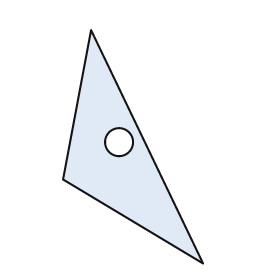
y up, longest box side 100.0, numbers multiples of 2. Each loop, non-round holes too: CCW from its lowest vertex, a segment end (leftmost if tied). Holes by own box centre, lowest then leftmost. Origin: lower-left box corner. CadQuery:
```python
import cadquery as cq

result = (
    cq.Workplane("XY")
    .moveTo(60.0, 0.0)
    .lineTo(12.0, 100.0)
    .lineTo(0.0, 36.0)
    .close()
    .moveTo(24.0, 52.0)
    .circle(6.0)
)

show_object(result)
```